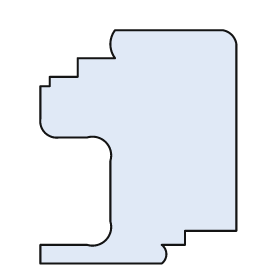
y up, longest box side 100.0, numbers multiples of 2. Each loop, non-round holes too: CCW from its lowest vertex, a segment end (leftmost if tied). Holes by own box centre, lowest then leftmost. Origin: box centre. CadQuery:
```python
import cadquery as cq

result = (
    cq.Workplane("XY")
    .moveTo(-42.0, -50.0)
    .lineTo(10.0, -50.0)
    .threePointArc((12.0, -46.0), (10.0, -42.0))
    .lineTo(20.0, -42.0)
    .lineTo(20.0, -36.0)
    .lineTo(42.0, -36.0)
    .lineTo(42.0, 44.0)
    .threePointArc((40.0, 48.0), (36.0, 50.0))
    .lineTo(-10.0, 50.0)
    .threePointArc((-12.0, 44.0), (-10.0, 38.0))
    .lineTo(-26.0, 38.0)
    .lineTo(-26.0, 30.0)
    .lineTo(-38.0, 30.0)
    .lineTo(-38.0, 26.0)
    .lineTo(-42.0, 26.0)
    .lineTo(-42.0, 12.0)
    .threePointArc((-40.0, 6.0), (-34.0, 4.0))
    .lineTo(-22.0, 4.0)
    .threePointArc((-14.0, 2.0), (-12.0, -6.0))
    .lineTo(-12.0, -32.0)
    .threePointArc((-14.0, -40.0), (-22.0, -42.0))
    .lineTo(-42.0, -42.0)
    .close()
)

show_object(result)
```